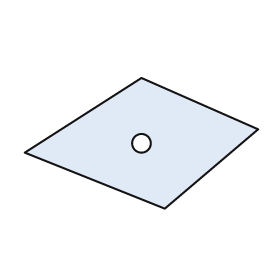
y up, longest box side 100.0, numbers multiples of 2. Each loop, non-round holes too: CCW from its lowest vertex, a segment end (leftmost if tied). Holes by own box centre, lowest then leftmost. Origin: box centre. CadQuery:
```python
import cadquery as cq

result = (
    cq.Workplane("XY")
    .moveTo(10.0, -28.0)
    .lineTo(50.0, 6.0)
    .lineTo(0.0, 28.0)
    .lineTo(-50.0, -4.0)
    .close()
    .moveTo(0.0, 0.0)
    .circle(4.0)
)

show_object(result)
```